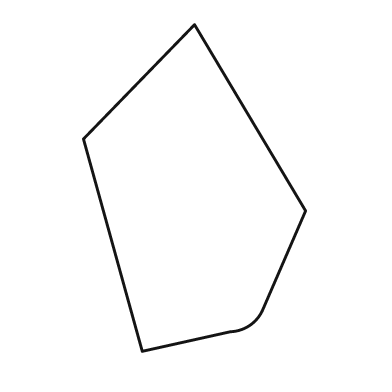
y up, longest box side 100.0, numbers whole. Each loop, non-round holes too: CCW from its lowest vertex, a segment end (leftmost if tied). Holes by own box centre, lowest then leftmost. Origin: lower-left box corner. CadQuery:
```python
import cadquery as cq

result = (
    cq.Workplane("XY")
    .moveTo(18.0, 0.0)
    .lineTo(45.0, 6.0)
    .threePointArc((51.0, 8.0), (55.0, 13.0))
    .lineTo(68.0, 43.0)
    .lineTo(34.0, 100.0)
    .lineTo(0.0, 65.0)
    .close()
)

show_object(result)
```